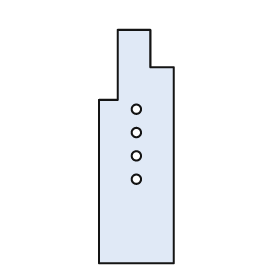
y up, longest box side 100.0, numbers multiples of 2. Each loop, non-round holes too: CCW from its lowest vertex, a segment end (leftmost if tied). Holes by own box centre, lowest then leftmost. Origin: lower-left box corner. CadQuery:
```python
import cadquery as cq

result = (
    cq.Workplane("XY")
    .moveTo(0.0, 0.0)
    .lineTo(32.0, 0.0)
    .lineTo(32.0, 84.0)
    .lineTo(22.0, 84.0)
    .lineTo(22.0, 100.0)
    .lineTo(8.0, 100.0)
    .lineTo(8.0, 70.0)
    .lineTo(0.0, 70.0)
    .close()
    .moveTo(16.0, 36.0)
    .circle(2.0)
    .moveTo(16.0, 46.0)
    .circle(2.0)
    .moveTo(16.0, 56.0)
    .circle(2.0)
    .moveTo(16.0, 66.0)
    .circle(2.0)
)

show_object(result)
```